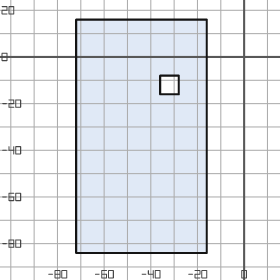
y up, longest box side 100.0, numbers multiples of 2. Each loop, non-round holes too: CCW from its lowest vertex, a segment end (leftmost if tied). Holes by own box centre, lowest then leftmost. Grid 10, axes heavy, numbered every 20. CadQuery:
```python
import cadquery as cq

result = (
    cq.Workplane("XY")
    .moveTo(-72.0, -84.0)
    .lineTo(-16.0, -84.0)
    .lineTo(-16.0, 16.0)
    .lineTo(-72.0, 16.0)
    .close()
    .moveTo(-36.0, -16.0)
    .lineTo(-28.0, -16.0)
    .lineTo(-28.0, -8.0)
    .lineTo(-36.0, -8.0)
    .close()
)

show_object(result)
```